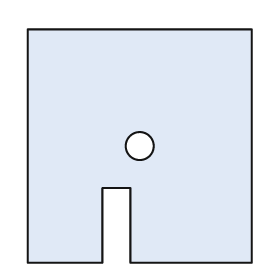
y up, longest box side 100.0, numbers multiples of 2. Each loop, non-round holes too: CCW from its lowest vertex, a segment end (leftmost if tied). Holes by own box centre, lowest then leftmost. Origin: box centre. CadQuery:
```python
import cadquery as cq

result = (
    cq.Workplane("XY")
    .moveTo(-48.0, -50.0)
    .lineTo(-16.0, -50.0)
    .lineTo(-16.0, -18.0)
    .lineTo(-4.0, -18.0)
    .lineTo(-4.0, -50.0)
    .lineTo(48.0, -50.0)
    .lineTo(48.0, 50.0)
    .lineTo(-48.0, 50.0)
    .close()
    .moveTo(0.0, 0.0)
    .circle(6.0)
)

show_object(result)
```